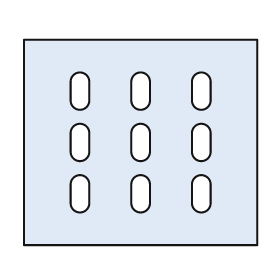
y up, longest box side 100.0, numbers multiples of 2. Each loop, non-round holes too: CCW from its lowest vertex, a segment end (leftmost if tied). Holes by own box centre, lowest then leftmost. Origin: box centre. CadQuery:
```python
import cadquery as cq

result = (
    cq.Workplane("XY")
    .moveTo(-50.0, -44.0)
    .lineTo(50.0, -44.0)
    .lineTo(50.0, 44.0)
    .lineTo(-50.0, 44.0)
    .close()
    .moveTo(-30.0, -26.0)
    .threePointArc((-26.0, -30.0), (-22.0, -26.0))
    .lineTo(-22.0, -18.0)
    .threePointArc((-26.0, -14.0), (-30.0, -18.0))
    .close()
    .moveTo(-4.0, -26.0)
    .threePointArc((0.0, -30.0), (4.0, -26.0))
    .lineTo(4.0, -18.0)
    .threePointArc((0.0, -14.0), (-4.0, -18.0))
    .close()
    .moveTo(22.0, -26.0)
    .threePointArc((26.0, -30.0), (30.0, -26.0))
    .lineTo(30.0, -18.0)
    .threePointArc((26.0, -14.0), (22.0, -18.0))
    .close()
    .moveTo(-30.0, -4.0)
    .threePointArc((-26.0, -8.0), (-22.0, -4.0))
    .lineTo(-22.0, 4.0)
    .threePointArc((-26.0, 8.0), (-30.0, 4.0))
    .close()
    .moveTo(-4.0, -4.0)
    .threePointArc((0.0, -8.0), (4.0, -4.0))
    .lineTo(4.0, 4.0)
    .threePointArc((0.0, 8.0), (-4.0, 4.0))
    .close()
    .moveTo(22.0, -4.0)
    .threePointArc((26.0, -8.0), (30.0, -4.0))
    .lineTo(30.0, 4.0)
    .threePointArc((26.0, 8.0), (22.0, 4.0))
    .close()
    .moveTo(-30.0, 18.0)
    .threePointArc((-26.0, 14.0), (-22.0, 18.0))
    .lineTo(-22.0, 26.0)
    .threePointArc((-26.0, 30.0), (-30.0, 26.0))
    .close()
    .moveTo(-4.0, 18.0)
    .threePointArc((0.0, 14.0), (4.0, 18.0))
    .lineTo(4.0, 26.0)
    .threePointArc((0.0, 30.0), (-4.0, 26.0))
    .close()
    .moveTo(22.0, 18.0)
    .threePointArc((26.0, 14.0), (30.0, 18.0))
    .lineTo(30.0, 26.0)
    .threePointArc((26.0, 30.0), (22.0, 26.0))
    .close()
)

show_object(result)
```